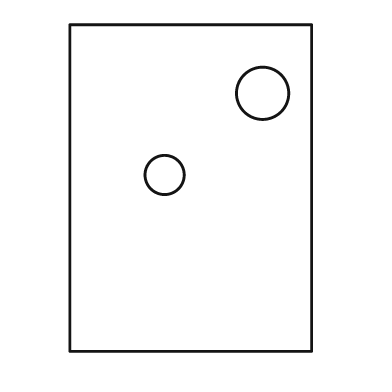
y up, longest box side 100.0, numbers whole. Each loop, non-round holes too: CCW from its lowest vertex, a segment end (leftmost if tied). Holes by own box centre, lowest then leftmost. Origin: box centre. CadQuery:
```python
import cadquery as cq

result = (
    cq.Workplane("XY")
    .moveTo(-37.0, -50.0)
    .lineTo(37.0, -50.0)
    .lineTo(37.0, 50.0)
    .lineTo(-37.0, 50.0)
    .close()
    .moveTo(-8.0, 4.0)
    .circle(6.0)
    .moveTo(22.0, 29.0)
    .circle(8.0)
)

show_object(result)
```